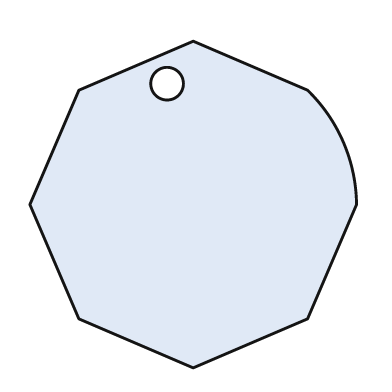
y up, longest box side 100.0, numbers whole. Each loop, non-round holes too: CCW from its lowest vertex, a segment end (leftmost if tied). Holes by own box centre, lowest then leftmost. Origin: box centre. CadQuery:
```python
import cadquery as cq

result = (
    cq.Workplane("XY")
    .moveTo(0.0, -50.0)
    .lineTo(35.0, -35.0)
    .lineTo(50.0, 0.0)
    .threePointArc((46.0, 19.0), (35.0, 35.0))
    .lineTo(0.0, 50.0)
    .lineTo(-35.0, 35.0)
    .lineTo(-50.0, 0.0)
    .lineTo(-35.0, -35.0)
    .close()
    .moveTo(-8.0, 37.0)
    .circle(5.0)
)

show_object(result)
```